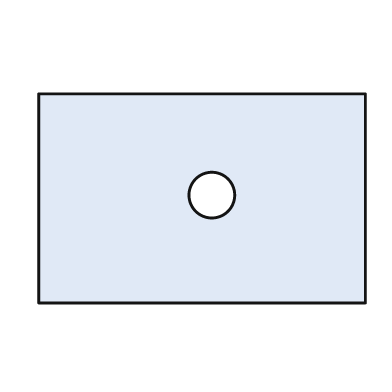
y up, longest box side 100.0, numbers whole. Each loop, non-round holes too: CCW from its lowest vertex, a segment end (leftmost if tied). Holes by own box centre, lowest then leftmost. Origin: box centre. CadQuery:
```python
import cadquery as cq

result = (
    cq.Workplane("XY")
    .moveTo(-50.0, -32.0)
    .lineTo(50.0, -32.0)
    .lineTo(50.0, 32.0)
    .lineTo(-50.0, 32.0)
    .close()
    .moveTo(3.0, 1.0)
    .circle(7.0)
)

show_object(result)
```